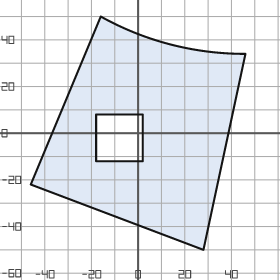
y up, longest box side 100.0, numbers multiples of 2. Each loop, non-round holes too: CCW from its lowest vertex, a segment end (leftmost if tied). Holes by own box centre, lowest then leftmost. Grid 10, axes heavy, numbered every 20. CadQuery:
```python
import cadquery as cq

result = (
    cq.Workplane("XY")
    .moveTo(28.0, -50.0)
    .lineTo(46.0, 34.0)
    .threePointArc((14.0, 38.0), (-16.0, 50.0))
    .lineTo(-46.0, -22.0)
    .close()
    .moveTo(-18.0, -12.0)
    .lineTo(2.0, -12.0)
    .lineTo(2.0, 8.0)
    .lineTo(-18.0, 8.0)
    .close()
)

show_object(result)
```